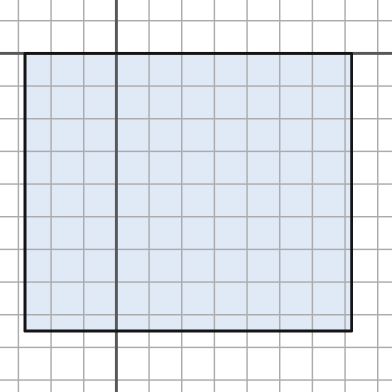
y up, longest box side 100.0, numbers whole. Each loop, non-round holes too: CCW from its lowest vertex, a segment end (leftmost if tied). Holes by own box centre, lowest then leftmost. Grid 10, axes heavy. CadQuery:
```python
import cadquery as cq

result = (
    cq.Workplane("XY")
    .moveTo(-28.0, -85.0)
    .lineTo(72.0, -85.0)
    .lineTo(72.0, 0.0)
    .lineTo(-28.0, 0.0)
    .close()
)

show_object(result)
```